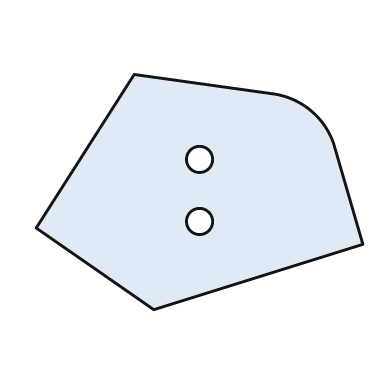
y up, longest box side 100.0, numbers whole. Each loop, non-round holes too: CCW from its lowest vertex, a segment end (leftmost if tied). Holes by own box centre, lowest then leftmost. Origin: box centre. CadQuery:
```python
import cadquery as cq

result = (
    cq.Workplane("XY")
    .moveTo(-14.0, -36.0)
    .lineTo(50.0, -16.0)
    .lineTo(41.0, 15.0)
    .threePointArc((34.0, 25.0), (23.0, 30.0))
    .lineTo(-20.0, 36.0)
    .lineTo(-50.0, -11.0)
    .close()
    .moveTo(0.0, -9.0)
    .circle(4.0)
    .moveTo(0.0, 10.0)
    .circle(4.0)
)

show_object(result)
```